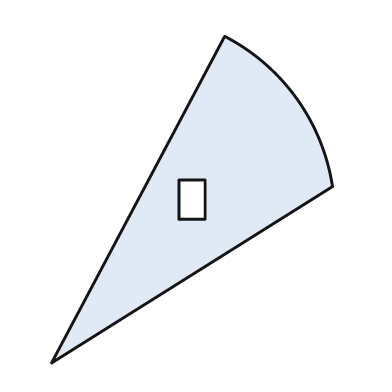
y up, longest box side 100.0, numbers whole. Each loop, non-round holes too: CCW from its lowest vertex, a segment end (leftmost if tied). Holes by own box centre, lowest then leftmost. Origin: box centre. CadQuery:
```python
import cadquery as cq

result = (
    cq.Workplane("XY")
    .moveTo(-43.0, -50.0)
    .lineTo(43.0, 4.0)
    .threePointArc((32.0, 31.0), (10.0, 50.0))
    .close()
    .moveTo(-4.0, -6.0)
    .lineTo(4.0, -6.0)
    .lineTo(4.0, 6.0)
    .lineTo(-4.0, 6.0)
    .close()
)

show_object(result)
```